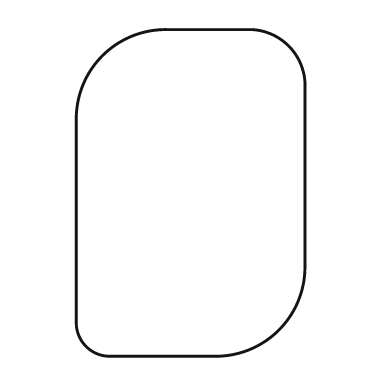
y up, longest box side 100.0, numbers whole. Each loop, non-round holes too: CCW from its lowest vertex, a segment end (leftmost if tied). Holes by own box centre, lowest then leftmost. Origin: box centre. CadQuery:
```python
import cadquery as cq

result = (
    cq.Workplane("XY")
    .moveTo(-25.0, -50.0)
    .lineTo(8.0, -50.0)
    .threePointArc((27.0, -42.0), (35.0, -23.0))
    .lineTo(35.0, 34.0)
    .threePointArc((30.0, 45.0), (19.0, 50.0))
    .lineTo(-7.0, 50.0)
    .threePointArc((-27.0, 42.0), (-35.0, 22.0))
    .lineTo(-35.0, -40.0)
    .threePointArc((-32.0, -47.0), (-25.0, -50.0))
    .close()
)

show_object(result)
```